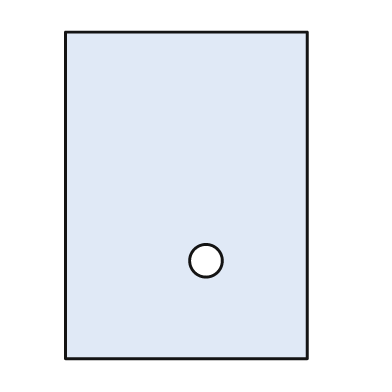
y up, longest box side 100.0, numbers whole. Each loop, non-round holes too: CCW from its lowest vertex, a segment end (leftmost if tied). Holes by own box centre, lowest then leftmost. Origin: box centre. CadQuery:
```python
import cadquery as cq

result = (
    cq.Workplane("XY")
    .moveTo(-37.0, -50.0)
    .lineTo(37.0, -50.0)
    .lineTo(37.0, 50.0)
    .lineTo(-37.0, 50.0)
    .close()
    .moveTo(6.0, -20.0)
    .circle(5.0)
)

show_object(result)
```